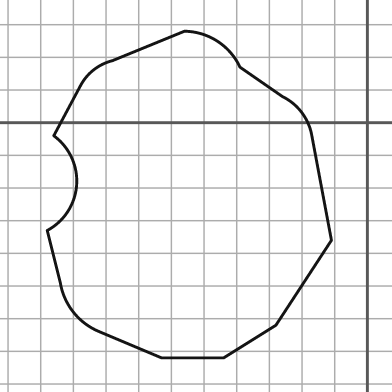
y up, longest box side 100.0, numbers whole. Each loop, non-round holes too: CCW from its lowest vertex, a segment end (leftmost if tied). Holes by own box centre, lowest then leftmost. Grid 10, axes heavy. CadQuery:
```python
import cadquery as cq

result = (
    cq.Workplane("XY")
    .moveTo(-63.0, -72.0)
    .lineTo(-44.0, -72.0)
    .lineTo(-28.0, -62.0)
    .lineTo(-11.0, -36.0)
    .lineTo(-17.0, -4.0)
    .threePointArc((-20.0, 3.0), (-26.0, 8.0))
    .lineTo(-39.0, 17.0)
    .threePointArc((-46.0, 25.0), (-56.0, 28.0))
    .lineTo(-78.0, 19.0)
    .threePointArc((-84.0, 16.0), (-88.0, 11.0))
    .lineTo(-96.0, -4.0)
    .threePointArc((-89.0, -19.0), (-98.0, -33.0))
    .lineTo(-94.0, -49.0)
    .threePointArc((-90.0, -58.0), (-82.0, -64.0))
    .close()
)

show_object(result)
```